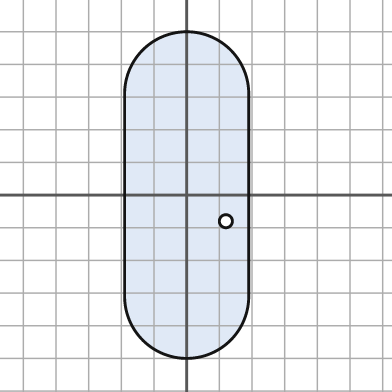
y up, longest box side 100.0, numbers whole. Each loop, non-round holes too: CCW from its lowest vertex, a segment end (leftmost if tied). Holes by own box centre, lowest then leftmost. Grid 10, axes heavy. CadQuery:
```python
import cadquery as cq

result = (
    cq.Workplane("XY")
    .moveTo(-19.0, -31.0)
    .threePointArc((0.0, -50.0), (19.0, -31.0))
    .lineTo(19.0, 31.0)
    .threePointArc((0.0, 50.0), (-19.0, 31.0))
    .close()
    .moveTo(12.0, -8.0)
    .circle(2.0)
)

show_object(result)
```